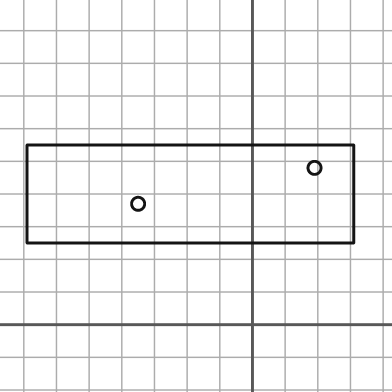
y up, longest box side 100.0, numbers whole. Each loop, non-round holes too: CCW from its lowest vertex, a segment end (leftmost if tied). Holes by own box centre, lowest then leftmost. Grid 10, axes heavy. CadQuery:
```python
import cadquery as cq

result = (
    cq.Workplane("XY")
    .moveTo(-69.0, 25.0)
    .lineTo(31.0, 25.0)
    .lineTo(31.0, 55.0)
    .lineTo(-69.0, 55.0)
    .close()
    .moveTo(-35.0, 37.0)
    .circle(2.0)
    .moveTo(19.0, 48.0)
    .circle(2.0)
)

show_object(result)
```